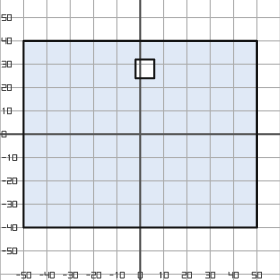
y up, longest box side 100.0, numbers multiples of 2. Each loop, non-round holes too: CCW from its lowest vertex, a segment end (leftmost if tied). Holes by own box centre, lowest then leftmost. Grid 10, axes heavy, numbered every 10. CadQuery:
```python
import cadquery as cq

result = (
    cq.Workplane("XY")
    .moveTo(-50.0, -40.0)
    .lineTo(50.0, -40.0)
    .lineTo(50.0, 40.0)
    .lineTo(-50.0, 40.0)
    .close()
    .moveTo(-2.0, 24.0)
    .lineTo(6.0, 24.0)
    .lineTo(6.0, 32.0)
    .lineTo(-2.0, 32.0)
    .close()
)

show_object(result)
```